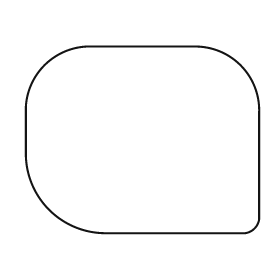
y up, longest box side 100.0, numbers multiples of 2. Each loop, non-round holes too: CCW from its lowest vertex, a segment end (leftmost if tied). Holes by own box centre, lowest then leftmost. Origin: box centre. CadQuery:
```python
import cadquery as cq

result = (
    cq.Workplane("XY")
    .moveTo(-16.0, -40.0)
    .lineTo(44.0, -40.0)
    .threePointArc((48.0, -38.0), (50.0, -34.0))
    .lineTo(50.0, 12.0)
    .threePointArc((42.0, 32.0), (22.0, 40.0))
    .lineTo(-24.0, 40.0)
    .threePointArc((-42.0, 32.0), (-50.0, 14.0))
    .lineTo(-50.0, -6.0)
    .threePointArc((-40.0, -30.0), (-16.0, -40.0))
    .close()
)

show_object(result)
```